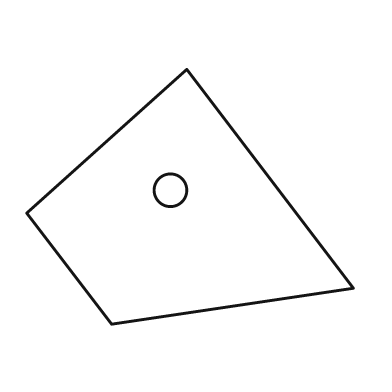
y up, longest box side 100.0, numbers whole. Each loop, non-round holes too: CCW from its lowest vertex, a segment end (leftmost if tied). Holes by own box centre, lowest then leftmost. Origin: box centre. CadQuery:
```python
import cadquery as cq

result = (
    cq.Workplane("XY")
    .moveTo(-24.0, -39.0)
    .lineTo(50.0, -28.0)
    .lineTo(-1.0, 39.0)
    .lineTo(-50.0, -5.0)
    .close()
    .moveTo(-6.0, 2.0)
    .circle(5.0)
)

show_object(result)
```